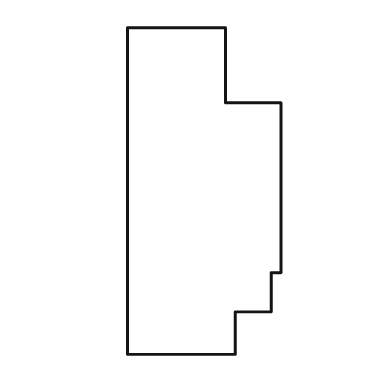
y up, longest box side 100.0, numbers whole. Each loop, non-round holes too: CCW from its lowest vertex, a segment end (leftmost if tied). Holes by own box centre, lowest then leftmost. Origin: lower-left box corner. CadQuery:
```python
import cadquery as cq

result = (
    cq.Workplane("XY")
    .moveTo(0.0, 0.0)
    .lineTo(33.0, 0.0)
    .lineTo(33.0, 13.0)
    .lineTo(44.0, 13.0)
    .lineTo(44.0, 25.0)
    .lineTo(47.0, 25.0)
    .lineTo(47.0, 77.0)
    .lineTo(30.0, 77.0)
    .lineTo(30.0, 100.0)
    .lineTo(0.0, 100.0)
    .close()
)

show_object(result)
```